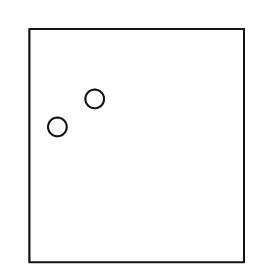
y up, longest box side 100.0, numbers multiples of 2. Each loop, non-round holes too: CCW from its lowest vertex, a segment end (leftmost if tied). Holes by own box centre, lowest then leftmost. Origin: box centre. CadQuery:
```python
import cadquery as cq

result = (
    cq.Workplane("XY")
    .moveTo(-46.0, -50.0)
    .lineTo(46.0, -50.0)
    .lineTo(46.0, 50.0)
    .lineTo(-46.0, 50.0)
    .close()
    .moveTo(-34.0, 8.0)
    .circle(4.0)
    .moveTo(-18.0, 20.0)
    .circle(4.0)
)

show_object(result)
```